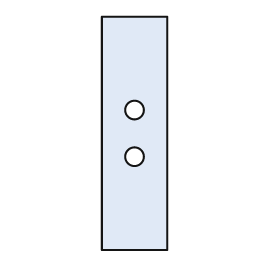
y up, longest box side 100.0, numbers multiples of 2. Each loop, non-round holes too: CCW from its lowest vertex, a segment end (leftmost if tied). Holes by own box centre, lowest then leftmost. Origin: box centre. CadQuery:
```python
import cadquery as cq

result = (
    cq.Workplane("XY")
    .moveTo(-14.0, -50.0)
    .lineTo(14.0, -50.0)
    .lineTo(14.0, 50.0)
    .lineTo(-14.0, 50.0)
    .close()
    .moveTo(0.0, -10.0)
    .circle(4.0)
    .moveTo(0.0, 10.0)
    .circle(4.0)
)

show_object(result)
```